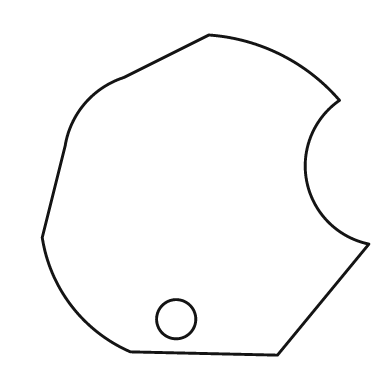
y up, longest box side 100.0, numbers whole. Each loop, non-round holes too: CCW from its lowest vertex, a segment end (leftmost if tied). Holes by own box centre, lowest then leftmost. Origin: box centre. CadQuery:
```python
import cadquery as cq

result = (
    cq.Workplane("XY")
    .moveTo(22.0, -49.0)
    .lineTo(50.0, -15.0)
    .threePointArc((31.0, 4.0), (41.0, 29.0))
    .threePointArc((23.0, 43.0), (1.0, 49.0))
    .lineTo(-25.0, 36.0)
    .threePointArc((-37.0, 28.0), (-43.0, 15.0))
    .lineTo(-50.0, -13.0)
    .threePointArc((-41.0, -34.0), (-23.0, -48.0))
    .close()
    .moveTo(-9.0, -38.0)
    .circle(6.0)
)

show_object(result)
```